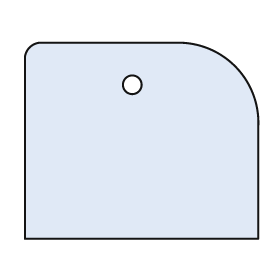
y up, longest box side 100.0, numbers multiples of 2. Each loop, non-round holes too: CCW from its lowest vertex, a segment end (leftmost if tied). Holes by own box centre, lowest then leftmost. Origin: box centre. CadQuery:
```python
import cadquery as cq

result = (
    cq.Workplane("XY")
    .moveTo(-50.0, -42.0)
    .lineTo(50.0, -42.0)
    .lineTo(50.0, 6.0)
    .threePointArc((40.0, 32.0), (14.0, 42.0))
    .lineTo(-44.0, 42.0)
    .threePointArc((-48.0, 40.0), (-50.0, 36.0))
    .close()
    .moveTo(-4.0, 24.0)
    .circle(4.0)
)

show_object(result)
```